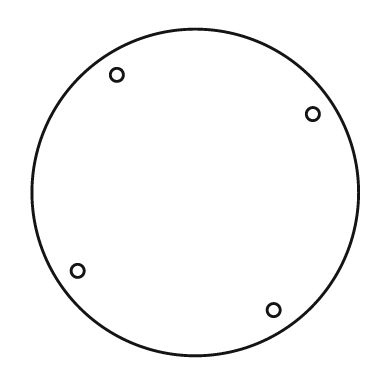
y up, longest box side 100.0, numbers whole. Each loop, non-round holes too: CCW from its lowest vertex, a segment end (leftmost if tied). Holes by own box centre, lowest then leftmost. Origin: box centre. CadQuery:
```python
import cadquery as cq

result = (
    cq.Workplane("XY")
    .moveTo(0.0, 0.0)
    .circle(50.0)
    .moveTo(24.0, -36.0)
    .circle(2.0)
    .moveTo(-36.0, -24.0)
    .circle(2.0)
    .moveTo(36.0, 24.0)
    .circle(2.0)
    .moveTo(-24.0, 36.0)
    .circle(2.0)
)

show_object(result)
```